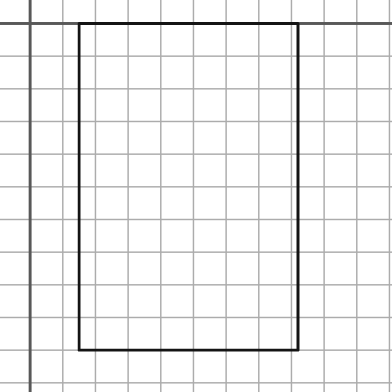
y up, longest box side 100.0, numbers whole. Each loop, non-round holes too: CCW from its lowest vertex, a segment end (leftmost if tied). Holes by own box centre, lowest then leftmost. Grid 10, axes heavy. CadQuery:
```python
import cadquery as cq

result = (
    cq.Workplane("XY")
    .moveTo(15.0, -100.0)
    .lineTo(82.0, -100.0)
    .lineTo(82.0, 0.0)
    .lineTo(15.0, 0.0)
    .close()
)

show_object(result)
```